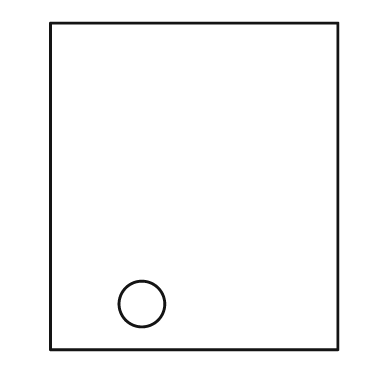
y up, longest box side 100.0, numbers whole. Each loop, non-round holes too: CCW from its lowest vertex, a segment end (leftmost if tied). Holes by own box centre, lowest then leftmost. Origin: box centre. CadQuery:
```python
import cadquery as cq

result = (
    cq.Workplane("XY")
    .moveTo(-44.0, -50.0)
    .lineTo(44.0, -50.0)
    .lineTo(44.0, 50.0)
    .lineTo(-44.0, 50.0)
    .close()
    .moveTo(-16.0, -36.0)
    .circle(7.0)
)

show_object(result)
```